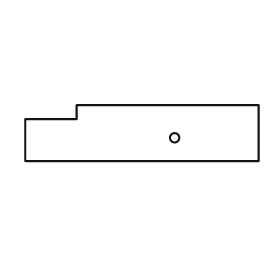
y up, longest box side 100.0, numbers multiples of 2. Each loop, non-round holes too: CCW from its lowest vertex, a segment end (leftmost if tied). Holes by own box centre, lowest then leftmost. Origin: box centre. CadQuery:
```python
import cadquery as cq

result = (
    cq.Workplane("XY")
    .moveTo(-50.0, -12.0)
    .lineTo(50.0, -12.0)
    .lineTo(50.0, 12.0)
    .lineTo(-28.0, 12.0)
    .lineTo(-28.0, 6.0)
    .lineTo(-50.0, 6.0)
    .close()
    .moveTo(14.0, -2.0)
    .circle(2.0)
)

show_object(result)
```